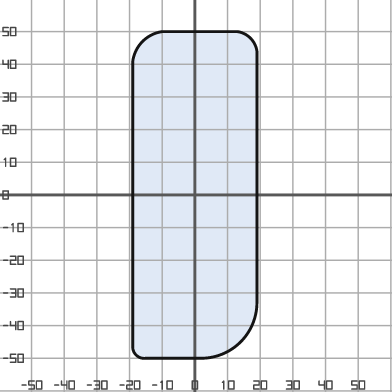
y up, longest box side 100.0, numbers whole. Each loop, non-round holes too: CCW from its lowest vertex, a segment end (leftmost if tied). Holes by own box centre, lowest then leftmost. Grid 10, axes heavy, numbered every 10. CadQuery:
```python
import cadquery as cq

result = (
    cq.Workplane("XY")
    .moveTo(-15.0, -50.0)
    .lineTo(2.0, -50.0)
    .threePointArc((14.0, -45.0), (19.0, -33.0))
    .lineTo(19.0, 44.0)
    .threePointArc((17.0, 48.0), (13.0, 50.0))
    .lineTo(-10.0, 50.0)
    .threePointArc((-16.0, 47.0), (-19.0, 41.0))
    .lineTo(-19.0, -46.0)
    .threePointArc((-18.0, -49.0), (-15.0, -50.0))
    .close()
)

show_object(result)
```